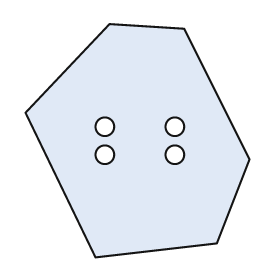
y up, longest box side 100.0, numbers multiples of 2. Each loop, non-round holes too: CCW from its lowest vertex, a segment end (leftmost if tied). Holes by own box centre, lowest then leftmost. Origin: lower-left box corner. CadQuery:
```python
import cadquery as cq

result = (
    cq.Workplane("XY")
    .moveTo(30.0, 0.0)
    .lineTo(82.0, 6.0)
    .lineTo(96.0, 42.0)
    .lineTo(68.0, 98.0)
    .lineTo(36.0, 100.0)
    .lineTo(0.0, 62.0)
    .close()
    .moveTo(34.0, 44.0)
    .circle(4.0)
    .moveTo(64.0, 44.0)
    .circle(4.0)
    .moveTo(34.0, 56.0)
    .circle(4.0)
    .moveTo(64.0, 56.0)
    .circle(4.0)
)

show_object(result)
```